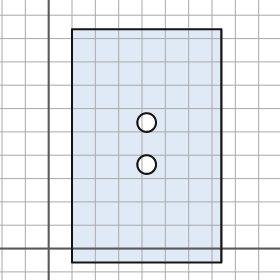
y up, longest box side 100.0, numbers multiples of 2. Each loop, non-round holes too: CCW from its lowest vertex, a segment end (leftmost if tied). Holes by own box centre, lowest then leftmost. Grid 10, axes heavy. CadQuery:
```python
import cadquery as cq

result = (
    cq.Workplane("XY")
    .moveTo(10.0, -6.0)
    .lineTo(74.0, -6.0)
    .lineTo(74.0, 94.0)
    .lineTo(10.0, 94.0)
    .close()
    .moveTo(42.0, 36.0)
    .circle(4.0)
    .moveTo(42.0, 54.0)
    .circle(4.0)
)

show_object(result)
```